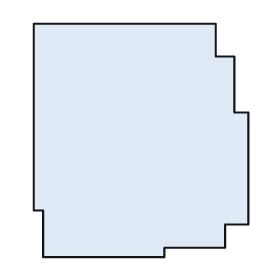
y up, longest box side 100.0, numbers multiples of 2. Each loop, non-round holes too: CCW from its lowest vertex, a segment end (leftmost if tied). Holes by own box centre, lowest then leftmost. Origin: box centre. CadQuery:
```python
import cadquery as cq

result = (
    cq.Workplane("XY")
    .moveTo(-42.0, -50.0)
    .lineTo(10.0, -50.0)
    .lineTo(10.0, -46.0)
    .lineTo(36.0, -46.0)
    .lineTo(36.0, -36.0)
    .lineTo(46.0, -36.0)
    .lineTo(46.0, 12.0)
    .lineTo(40.0, 12.0)
    .lineTo(40.0, 36.0)
    .lineTo(32.0, 36.0)
    .lineTo(32.0, 50.0)
    .lineTo(-46.0, 50.0)
    .lineTo(-46.0, -30.0)
    .lineTo(-42.0, -30.0)
    .close()
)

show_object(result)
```